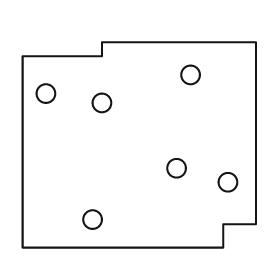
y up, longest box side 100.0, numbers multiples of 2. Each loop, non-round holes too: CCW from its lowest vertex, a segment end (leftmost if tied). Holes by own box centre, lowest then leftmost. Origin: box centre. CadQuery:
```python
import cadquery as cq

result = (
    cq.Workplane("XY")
    .moveTo(-50.0, -44.0)
    .lineTo(36.0, -44.0)
    .lineTo(36.0, -34.0)
    .lineTo(50.0, -34.0)
    .lineTo(50.0, 44.0)
    .lineTo(-16.0, 44.0)
    .lineTo(-16.0, 38.0)
    .lineTo(-50.0, 38.0)
    .close()
    .moveTo(-20.0, -32.0)
    .circle(4.0)
    .moveTo(38.0, -16.0)
    .circle(4.0)
    .moveTo(16.0, -10.0)
    .circle(4.0)
    .moveTo(-16.0, 18.0)
    .circle(4.0)
    .moveTo(-40.0, 22.0)
    .circle(4.0)
    .moveTo(22.0, 30.0)
    .circle(4.0)
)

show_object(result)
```